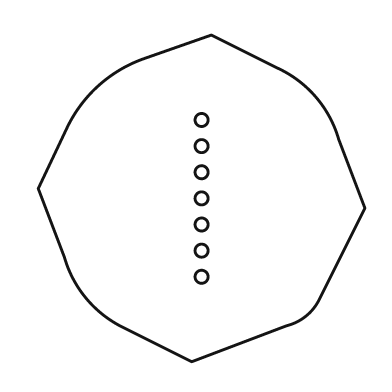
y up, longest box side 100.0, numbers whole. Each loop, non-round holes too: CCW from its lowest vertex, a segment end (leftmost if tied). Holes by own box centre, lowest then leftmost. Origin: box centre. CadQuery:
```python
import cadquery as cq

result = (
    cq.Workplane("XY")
    .moveTo(-3.0, -50.0)
    .lineTo(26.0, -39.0)
    .threePointArc((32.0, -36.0), (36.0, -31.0))
    .lineTo(50.0, -3.0)
    .lineTo(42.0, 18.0)
    .threePointArc((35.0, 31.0), (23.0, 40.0))
    .lineTo(3.0, 50.0)
    .lineTo(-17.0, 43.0)
    .threePointArc((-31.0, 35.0), (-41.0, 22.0))
    .lineTo(-50.0, 3.0)
    .lineTo(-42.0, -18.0)
    .threePointArc((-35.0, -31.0), (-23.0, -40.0))
    .close()
    .moveTo(0.0, -24.0)
    .circle(2.0)
    .moveTo(0.0, -16.0)
    .circle(2.0)
    .moveTo(0.0, -8.0)
    .circle(2.0)
    .moveTo(0.0, 0.0)
    .circle(2.0)
    .moveTo(0.0, 8.0)
    .circle(2.0)
    .moveTo(0.0, 16.0)
    .circle(2.0)
    .moveTo(0.0, 24.0)
    .circle(2.0)
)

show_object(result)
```